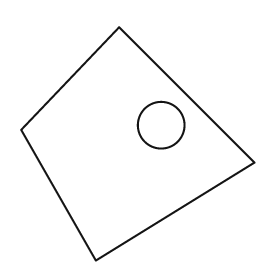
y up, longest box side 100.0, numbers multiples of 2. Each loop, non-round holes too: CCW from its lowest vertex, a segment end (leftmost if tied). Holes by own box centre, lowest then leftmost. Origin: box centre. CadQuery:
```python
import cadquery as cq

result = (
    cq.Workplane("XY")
    .moveTo(-18.0, -50.0)
    .lineTo(50.0, -8.0)
    .lineTo(-8.0, 50.0)
    .lineTo(-50.0, 6.0)
    .close()
    .moveTo(10.0, 8.0)
    .circle(10.0)
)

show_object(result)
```